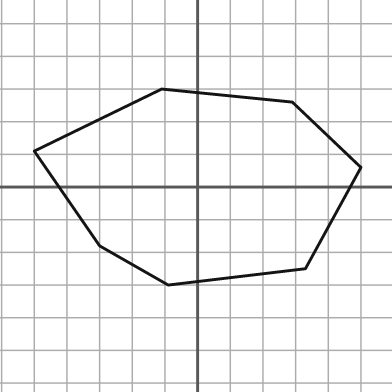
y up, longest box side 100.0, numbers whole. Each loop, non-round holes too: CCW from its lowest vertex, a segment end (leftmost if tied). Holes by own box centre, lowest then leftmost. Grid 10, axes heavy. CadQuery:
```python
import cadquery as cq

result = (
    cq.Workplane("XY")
    .moveTo(-9.0, -30.0)
    .lineTo(33.0, -25.0)
    .lineTo(50.0, 6.0)
    .lineTo(29.0, 26.0)
    .lineTo(-11.0, 30.0)
    .lineTo(-50.0, 11.0)
    .lineTo(-30.0, -18.0)
    .close()
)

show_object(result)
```